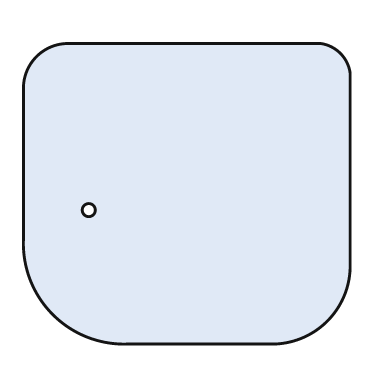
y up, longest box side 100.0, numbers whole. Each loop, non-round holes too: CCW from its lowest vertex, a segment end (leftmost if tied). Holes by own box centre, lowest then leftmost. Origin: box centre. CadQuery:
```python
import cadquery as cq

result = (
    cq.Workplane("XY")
    .moveTo(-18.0, -46.0)
    .lineTo(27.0, -46.0)
    .threePointArc((43.0, -39.0), (50.0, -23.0))
    .lineTo(50.0, 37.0)
    .threePointArc((47.0, 43.0), (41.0, 46.0))
    .lineTo(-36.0, 46.0)
    .threePointArc((-46.0, 42.0), (-50.0, 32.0))
    .lineTo(-50.0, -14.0)
    .threePointArc((-41.0, -37.0), (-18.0, -46.0))
    .close()
    .moveTo(-30.0, -5.0)
    .circle(2.0)
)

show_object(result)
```